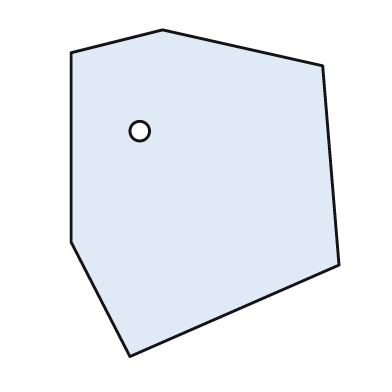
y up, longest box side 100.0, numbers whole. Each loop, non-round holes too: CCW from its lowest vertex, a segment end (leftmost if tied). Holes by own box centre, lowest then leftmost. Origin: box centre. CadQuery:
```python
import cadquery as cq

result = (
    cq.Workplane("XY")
    .moveTo(-23.0, -50.0)
    .lineTo(41.0, -22.0)
    .lineTo(36.0, 39.0)
    .lineTo(-13.0, 50.0)
    .lineTo(-41.0, 43.0)
    .lineTo(-41.0, -15.0)
    .close()
    .moveTo(-20.0, 19.0)
    .circle(3.0)
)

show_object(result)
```